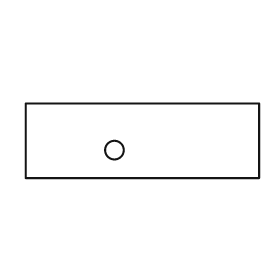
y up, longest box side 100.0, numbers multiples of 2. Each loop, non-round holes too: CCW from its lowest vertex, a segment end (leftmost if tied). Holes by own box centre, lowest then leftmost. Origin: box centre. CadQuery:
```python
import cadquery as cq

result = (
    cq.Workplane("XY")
    .moveTo(-50.0, -16.0)
    .lineTo(50.0, -16.0)
    .lineTo(50.0, 16.0)
    .lineTo(-50.0, 16.0)
    .close()
    .moveTo(-12.0, -4.0)
    .circle(4.0)
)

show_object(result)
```